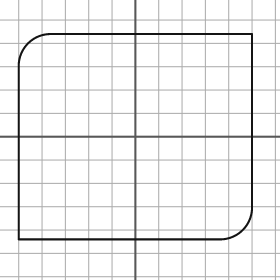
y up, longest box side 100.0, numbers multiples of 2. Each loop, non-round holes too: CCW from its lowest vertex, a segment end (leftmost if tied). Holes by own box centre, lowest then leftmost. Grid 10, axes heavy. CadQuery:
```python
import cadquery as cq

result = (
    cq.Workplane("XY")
    .moveTo(-50.0, -44.0)
    .lineTo(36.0, -44.0)
    .threePointArc((46.0, -40.0), (50.0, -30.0))
    .lineTo(50.0, 44.0)
    .lineTo(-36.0, 44.0)
    .threePointArc((-46.0, 40.0), (-50.0, 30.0))
    .close()
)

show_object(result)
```